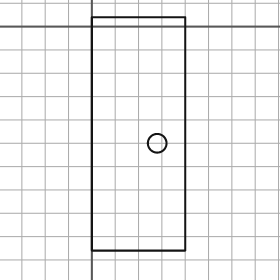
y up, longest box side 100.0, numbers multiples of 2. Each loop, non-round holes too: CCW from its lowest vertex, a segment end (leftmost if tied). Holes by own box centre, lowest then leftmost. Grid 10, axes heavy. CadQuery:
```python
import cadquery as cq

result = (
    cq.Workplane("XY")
    .moveTo(0.0, -96.0)
    .lineTo(40.0, -96.0)
    .lineTo(40.0, 4.0)
    .lineTo(0.0, 4.0)
    .close()
    .moveTo(28.0, -50.0)
    .circle(4.0)
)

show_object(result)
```